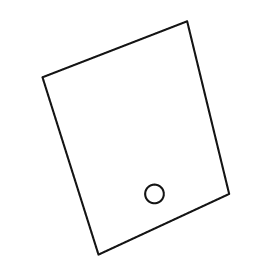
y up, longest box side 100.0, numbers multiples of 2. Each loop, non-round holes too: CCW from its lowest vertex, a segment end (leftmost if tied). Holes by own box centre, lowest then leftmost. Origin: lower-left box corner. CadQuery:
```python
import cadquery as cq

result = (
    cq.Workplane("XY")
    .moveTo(24.0, 0.0)
    .lineTo(80.0, 26.0)
    .lineTo(62.0, 100.0)
    .lineTo(0.0, 76.0)
    .close()
    .moveTo(48.0, 26.0)
    .circle(4.0)
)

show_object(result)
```